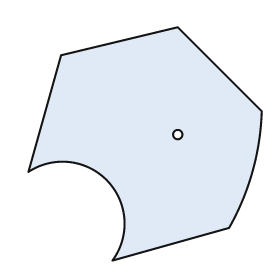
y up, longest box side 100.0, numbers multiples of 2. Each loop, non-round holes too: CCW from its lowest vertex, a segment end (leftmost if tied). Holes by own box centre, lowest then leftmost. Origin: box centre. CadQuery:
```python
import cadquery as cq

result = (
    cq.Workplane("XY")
    .moveTo(-14.0, -50.0)
    .lineTo(36.0, -36.0)
    .threePointArc((46.0, -12.0), (50.0, 14.0))
    .lineTo(14.0, 50.0)
    .lineTo(-36.0, 38.0)
    .lineTo(-50.0, -12.0)
    .threePointArc((-16.0, -16.0), (-14.0, -50.0))
    .close()
    .moveTo(14.0, 4.0)
    .circle(2.0)
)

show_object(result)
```